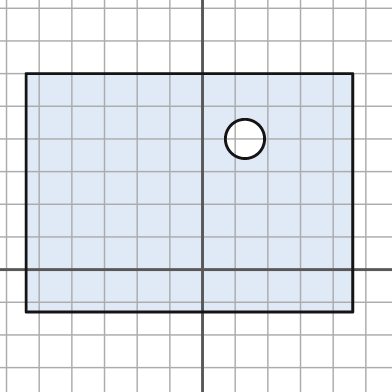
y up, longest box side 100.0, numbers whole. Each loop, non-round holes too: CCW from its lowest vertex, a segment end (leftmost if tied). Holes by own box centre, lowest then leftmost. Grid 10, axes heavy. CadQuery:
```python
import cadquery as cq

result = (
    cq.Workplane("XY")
    .moveTo(-54.0, -13.0)
    .lineTo(46.0, -13.0)
    .lineTo(46.0, 60.0)
    .lineTo(-54.0, 60.0)
    .close()
    .moveTo(13.0, 40.0)
    .circle(6.0)
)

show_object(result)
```